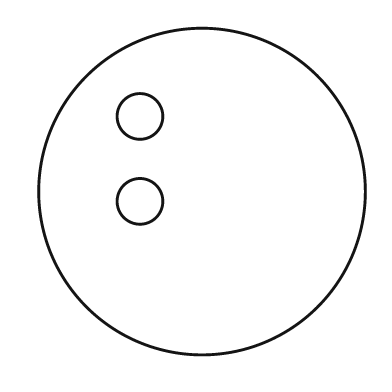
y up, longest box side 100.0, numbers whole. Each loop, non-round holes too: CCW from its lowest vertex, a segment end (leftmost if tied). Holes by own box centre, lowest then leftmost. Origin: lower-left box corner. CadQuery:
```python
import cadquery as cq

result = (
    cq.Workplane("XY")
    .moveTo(50.0, 50.0)
    .circle(50.0)
    .moveTo(31.0, 47.0)
    .circle(7.0)
    .moveTo(31.0, 73.0)
    .circle(7.0)
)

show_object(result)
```